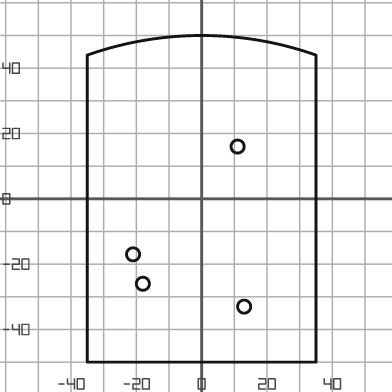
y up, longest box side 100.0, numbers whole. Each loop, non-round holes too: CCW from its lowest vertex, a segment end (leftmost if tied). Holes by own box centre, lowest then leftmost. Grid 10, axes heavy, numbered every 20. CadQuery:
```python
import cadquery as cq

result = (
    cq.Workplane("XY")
    .moveTo(-35.0, -50.0)
    .lineTo(35.0, -50.0)
    .lineTo(35.0, 44.0)
    .threePointArc((0.0, 50.0), (-35.0, 44.0))
    .close()
    .moveTo(13.0, -33.0)
    .circle(2.0)
    .moveTo(-18.0, -26.0)
    .circle(2.0)
    .moveTo(-21.0, -17.0)
    .circle(2.0)
    .moveTo(11.0, 16.0)
    .circle(2.0)
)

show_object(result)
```